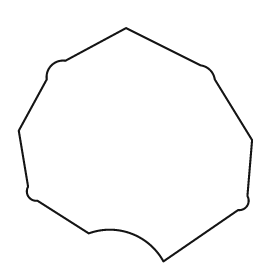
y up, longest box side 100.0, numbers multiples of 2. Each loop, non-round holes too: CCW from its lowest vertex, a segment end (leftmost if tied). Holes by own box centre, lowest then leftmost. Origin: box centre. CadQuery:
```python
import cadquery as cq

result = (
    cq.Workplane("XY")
    .moveTo(12.0, -50.0)
    .lineTo(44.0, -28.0)
    .threePointArc((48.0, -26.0), (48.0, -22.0))
    .lineTo(50.0, 2.0)
    .lineTo(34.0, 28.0)
    .threePointArc((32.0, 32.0), (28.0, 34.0))
    .lineTo(-4.0, 50.0)
    .lineTo(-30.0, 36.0)
    .threePointArc((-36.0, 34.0), (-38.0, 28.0))
    .lineTo(-50.0, 6.0)
    .lineTo(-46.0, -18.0)
    .threePointArc((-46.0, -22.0), (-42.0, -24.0))
    .lineTo(-20.0, -38.0)
    .threePointArc((-2.0, -38.0), (12.0, -50.0))
    .close()
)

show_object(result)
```